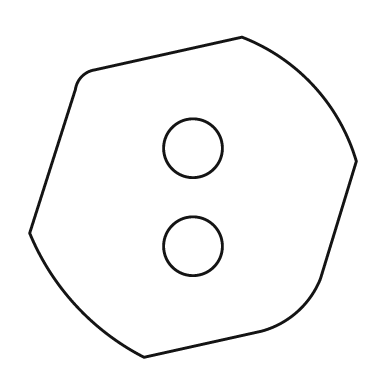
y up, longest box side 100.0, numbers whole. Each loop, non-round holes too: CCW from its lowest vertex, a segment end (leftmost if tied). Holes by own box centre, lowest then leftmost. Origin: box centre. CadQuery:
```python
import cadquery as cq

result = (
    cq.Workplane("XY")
    .moveTo(-15.0, -49.0)
    .lineTo(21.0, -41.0)
    .threePointArc((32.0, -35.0), (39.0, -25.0))
    .lineTo(50.0, 11.0)
    .threePointArc((37.0, 34.0), (15.0, 49.0))
    .lineTo(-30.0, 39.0)
    .threePointArc((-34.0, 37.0), (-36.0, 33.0))
    .lineTo(-50.0, -11.0)
    .threePointArc((-36.0, -33.0), (-15.0, -49.0))
    .close()
    .moveTo(0.0, -15.0)
    .circle(9.0)
    .moveTo(0.0, 15.0)
    .circle(9.0)
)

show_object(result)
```